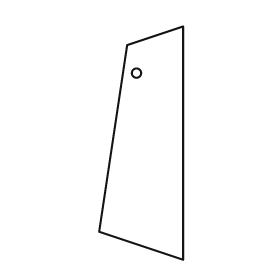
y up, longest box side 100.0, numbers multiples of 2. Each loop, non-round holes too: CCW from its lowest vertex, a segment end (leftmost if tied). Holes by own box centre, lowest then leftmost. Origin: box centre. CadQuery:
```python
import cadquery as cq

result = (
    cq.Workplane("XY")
    .moveTo(18.0, -50.0)
    .lineTo(18.0, 50.0)
    .lineTo(-6.0, 42.0)
    .lineTo(-18.0, -38.0)
    .close()
    .moveTo(-2.0, 30.0)
    .circle(2.0)
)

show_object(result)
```